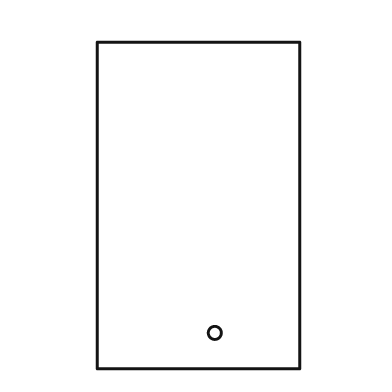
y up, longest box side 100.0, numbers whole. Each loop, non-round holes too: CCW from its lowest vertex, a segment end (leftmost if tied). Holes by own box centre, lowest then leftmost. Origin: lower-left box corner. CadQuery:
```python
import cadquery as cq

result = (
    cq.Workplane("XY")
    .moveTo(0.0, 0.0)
    .lineTo(62.0, 0.0)
    .lineTo(62.0, 100.0)
    .lineTo(0.0, 100.0)
    .close()
    .moveTo(36.0, 11.0)
    .circle(2.0)
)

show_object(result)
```